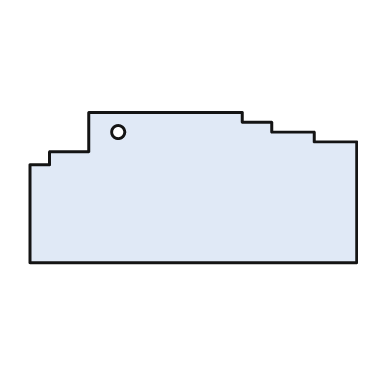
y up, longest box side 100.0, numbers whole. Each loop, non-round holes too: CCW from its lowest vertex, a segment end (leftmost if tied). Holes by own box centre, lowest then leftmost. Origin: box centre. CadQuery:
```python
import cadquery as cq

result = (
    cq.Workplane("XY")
    .moveTo(-50.0, -23.0)
    .lineTo(50.0, -23.0)
    .lineTo(50.0, 14.0)
    .lineTo(37.0, 14.0)
    .lineTo(37.0, 17.0)
    .lineTo(24.0, 17.0)
    .lineTo(24.0, 20.0)
    .lineTo(15.0, 20.0)
    .lineTo(15.0, 23.0)
    .lineTo(-32.0, 23.0)
    .lineTo(-32.0, 11.0)
    .lineTo(-44.0, 11.0)
    .lineTo(-44.0, 7.0)
    .lineTo(-50.0, 7.0)
    .close()
    .moveTo(-23.0, 17.0)
    .circle(2.0)
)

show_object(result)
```